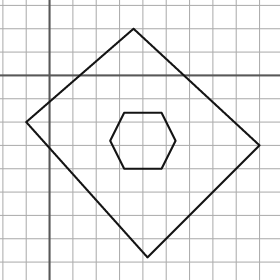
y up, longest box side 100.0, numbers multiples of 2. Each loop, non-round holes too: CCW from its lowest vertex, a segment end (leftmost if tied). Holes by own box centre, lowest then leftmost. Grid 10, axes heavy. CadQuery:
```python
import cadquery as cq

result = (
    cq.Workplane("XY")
    .moveTo(42.0, -78.0)
    .lineTo(90.0, -30.0)
    .lineTo(36.0, 20.0)
    .lineTo(-10.0, -20.0)
    .close()
    .moveTo(32.0, -40.0)
    .lineTo(48.0, -40.0)
    .lineTo(54.0, -28.0)
    .lineTo(48.0, -16.0)
    .lineTo(32.0, -16.0)
    .lineTo(26.0, -28.0)
    .close()
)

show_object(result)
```